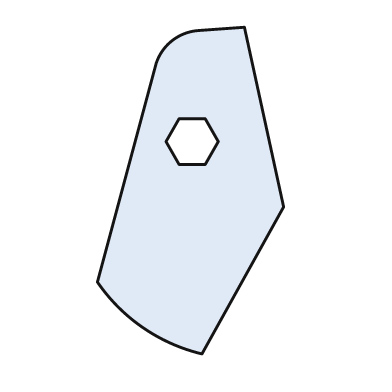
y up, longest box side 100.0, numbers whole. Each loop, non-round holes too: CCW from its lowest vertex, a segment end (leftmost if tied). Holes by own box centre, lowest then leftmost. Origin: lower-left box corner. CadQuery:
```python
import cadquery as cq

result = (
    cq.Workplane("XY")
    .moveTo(32.0, 0.0)
    .lineTo(57.0, 45.0)
    .lineTo(45.0, 100.0)
    .lineTo(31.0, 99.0)
    .threePointArc((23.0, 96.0), (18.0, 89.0))
    .lineTo(0.0, 22.0)
    .threePointArc((14.0, 8.0), (32.0, 0.0))
    .close()
    .moveTo(25.0, 58.0)
    .lineTo(33.0, 58.0)
    .lineTo(37.0, 65.0)
    .lineTo(33.0, 72.0)
    .lineTo(25.0, 72.0)
    .lineTo(21.0, 65.0)
    .close()
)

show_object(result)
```